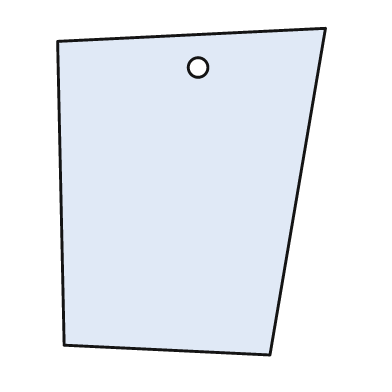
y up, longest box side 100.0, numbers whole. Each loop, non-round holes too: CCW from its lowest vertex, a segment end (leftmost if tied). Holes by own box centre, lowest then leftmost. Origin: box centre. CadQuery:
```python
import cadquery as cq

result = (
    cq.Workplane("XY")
    .moveTo(24.0, -50.0)
    .lineTo(41.0, 50.0)
    .lineTo(-41.0, 46.0)
    .lineTo(-39.0, -47.0)
    .close()
    .moveTo(2.0, 38.0)
    .circle(3.0)
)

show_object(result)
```